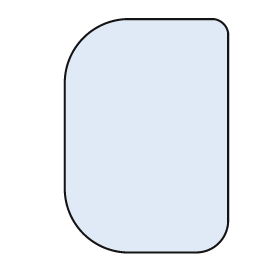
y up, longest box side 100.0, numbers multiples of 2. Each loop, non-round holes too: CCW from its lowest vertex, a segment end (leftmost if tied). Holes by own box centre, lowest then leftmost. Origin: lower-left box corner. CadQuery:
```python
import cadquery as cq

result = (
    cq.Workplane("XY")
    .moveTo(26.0, 0.0)
    .lineTo(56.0, 0.0)
    .threePointArc((66.0, 4.0), (70.0, 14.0))
    .lineTo(70.0, 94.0)
    .threePointArc((68.0, 98.0), (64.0, 100.0))
    .lineTo(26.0, 100.0)
    .threePointArc((8.0, 92.0), (0.0, 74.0))
    .lineTo(0.0, 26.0)
    .threePointArc((8.0, 8.0), (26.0, 0.0))
    .close()
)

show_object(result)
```